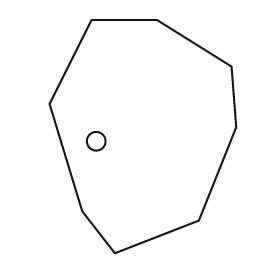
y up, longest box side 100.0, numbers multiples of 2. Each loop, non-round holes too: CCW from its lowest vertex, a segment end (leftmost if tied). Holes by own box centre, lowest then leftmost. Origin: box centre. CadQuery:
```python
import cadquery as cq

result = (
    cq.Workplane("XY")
    .moveTo(-12.0, -50.0)
    .lineTo(24.0, -36.0)
    .lineTo(40.0, 4.0)
    .lineTo(38.0, 30.0)
    .lineTo(6.0, 50.0)
    .lineTo(-22.0, 50.0)
    .lineTo(-40.0, 14.0)
    .lineTo(-26.0, -32.0)
    .close()
    .moveTo(-20.0, -2.0)
    .circle(4.0)
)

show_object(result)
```